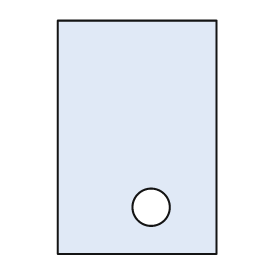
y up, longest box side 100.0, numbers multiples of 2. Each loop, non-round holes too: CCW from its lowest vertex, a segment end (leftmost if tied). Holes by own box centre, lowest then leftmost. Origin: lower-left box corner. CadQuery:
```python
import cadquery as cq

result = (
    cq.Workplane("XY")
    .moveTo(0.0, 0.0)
    .lineTo(68.0, 0.0)
    .lineTo(68.0, 100.0)
    .lineTo(0.0, 100.0)
    .close()
    .moveTo(40.0, 20.0)
    .circle(8.0)
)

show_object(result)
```